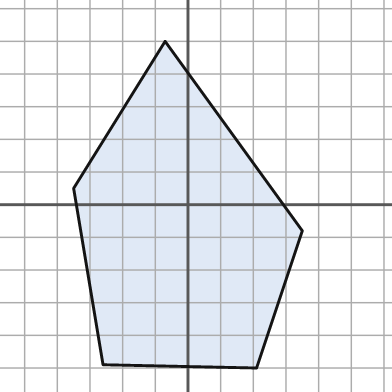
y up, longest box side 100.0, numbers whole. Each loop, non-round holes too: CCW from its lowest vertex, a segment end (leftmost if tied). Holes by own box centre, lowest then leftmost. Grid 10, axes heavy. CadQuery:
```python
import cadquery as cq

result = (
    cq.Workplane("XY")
    .moveTo(21.0, -50.0)
    .lineTo(35.0, -8.0)
    .lineTo(-7.0, 50.0)
    .lineTo(-35.0, 5.0)
    .lineTo(-26.0, -49.0)
    .close()
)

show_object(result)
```